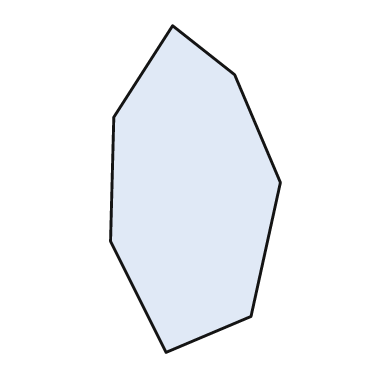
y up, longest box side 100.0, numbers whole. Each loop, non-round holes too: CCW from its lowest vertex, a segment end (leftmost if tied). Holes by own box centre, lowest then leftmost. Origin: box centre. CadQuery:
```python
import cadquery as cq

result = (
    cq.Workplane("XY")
    .moveTo(-9.0, -50.0)
    .lineTo(17.0, -39.0)
    .lineTo(26.0, 2.0)
    .lineTo(12.0, 35.0)
    .lineTo(-7.0, 50.0)
    .lineTo(-25.0, 22.0)
    .lineTo(-26.0, -16.0)
    .close()
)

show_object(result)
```